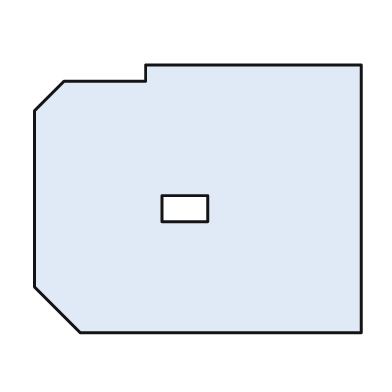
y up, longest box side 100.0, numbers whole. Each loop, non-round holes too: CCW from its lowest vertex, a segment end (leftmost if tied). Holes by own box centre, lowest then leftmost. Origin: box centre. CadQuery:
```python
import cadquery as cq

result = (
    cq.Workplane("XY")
    .moveTo(-36.0, -41.0)
    .lineTo(50.0, -41.0)
    .lineTo(50.0, 41.0)
    .lineTo(-16.0, 41.0)
    .lineTo(-16.0, 36.0)
    .lineTo(-41.0, 36.0)
    .lineTo(-50.0, 27.0)
    .lineTo(-50.0, -27.0)
    .close()
    .moveTo(-11.0, -7.0)
    .lineTo(3.0, -7.0)
    .lineTo(3.0, 1.0)
    .lineTo(-11.0, 1.0)
    .close()
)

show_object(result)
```